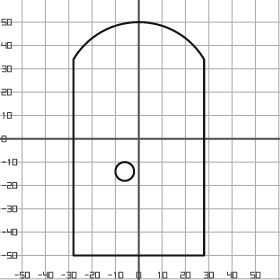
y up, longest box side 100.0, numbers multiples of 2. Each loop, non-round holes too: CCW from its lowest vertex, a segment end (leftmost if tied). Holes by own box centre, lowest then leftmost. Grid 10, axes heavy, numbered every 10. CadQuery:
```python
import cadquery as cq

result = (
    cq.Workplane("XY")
    .moveTo(-28.0, -50.0)
    .lineTo(28.0, -50.0)
    .lineTo(28.0, 34.0)
    .threePointArc((0.0, 50.0), (-28.0, 34.0))
    .close()
    .moveTo(-6.0, -14.0)
    .circle(4.0)
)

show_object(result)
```